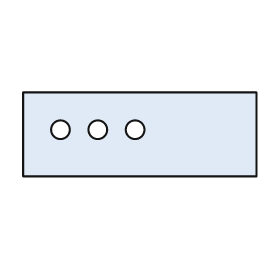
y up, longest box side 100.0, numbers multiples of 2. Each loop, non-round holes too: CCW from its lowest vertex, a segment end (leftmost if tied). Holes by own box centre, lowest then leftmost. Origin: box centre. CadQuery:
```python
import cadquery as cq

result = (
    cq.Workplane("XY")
    .moveTo(-50.0, -18.0)
    .lineTo(50.0, -18.0)
    .lineTo(50.0, 18.0)
    .lineTo(-50.0, 18.0)
    .close()
    .moveTo(-34.0, 2.0)
    .circle(4.0)
    .moveTo(-18.0, 2.0)
    .circle(4.0)
    .moveTo(-2.0, 2.0)
    .circle(4.0)
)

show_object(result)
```